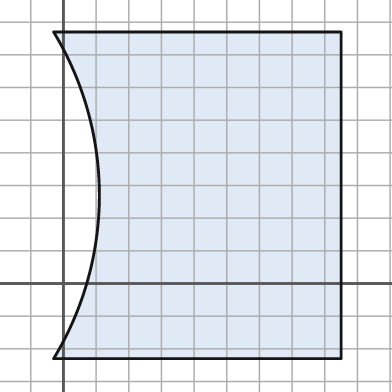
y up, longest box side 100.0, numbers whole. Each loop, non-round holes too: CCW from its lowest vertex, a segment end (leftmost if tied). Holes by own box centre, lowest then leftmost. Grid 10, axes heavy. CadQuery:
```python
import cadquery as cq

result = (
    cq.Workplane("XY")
    .moveTo(-3.0, -23.0)
    .lineTo(85.0, -23.0)
    .lineTo(85.0, 77.0)
    .lineTo(-3.0, 77.0)
    .threePointArc((11.0, 27.0), (-3.0, -23.0))
    .close()
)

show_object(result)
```